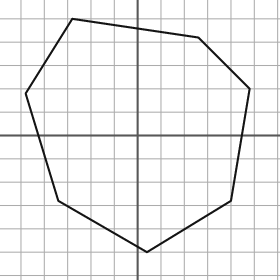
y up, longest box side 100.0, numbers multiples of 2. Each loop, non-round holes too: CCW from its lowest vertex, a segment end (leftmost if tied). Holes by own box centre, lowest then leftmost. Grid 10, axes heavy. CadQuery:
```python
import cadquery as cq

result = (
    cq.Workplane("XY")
    .moveTo(4.0, -50.0)
    .lineTo(40.0, -28.0)
    .lineTo(48.0, 20.0)
    .lineTo(26.0, 42.0)
    .lineTo(-28.0, 50.0)
    .lineTo(-48.0, 18.0)
    .lineTo(-34.0, -28.0)
    .close()
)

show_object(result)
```